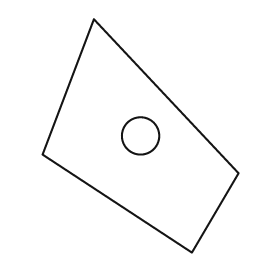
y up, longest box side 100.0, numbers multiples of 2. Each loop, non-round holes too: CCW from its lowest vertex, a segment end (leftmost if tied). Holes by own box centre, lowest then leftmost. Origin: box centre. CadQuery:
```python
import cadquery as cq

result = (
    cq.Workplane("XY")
    .moveTo(22.0, -50.0)
    .lineTo(42.0, -16.0)
    .lineTo(-20.0, 50.0)
    .lineTo(-42.0, -8.0)
    .close()
    .moveTo(0.0, 0.0)
    .circle(8.0)
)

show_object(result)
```